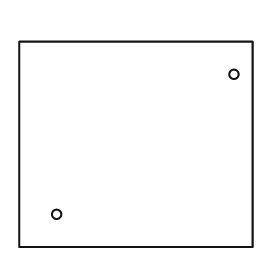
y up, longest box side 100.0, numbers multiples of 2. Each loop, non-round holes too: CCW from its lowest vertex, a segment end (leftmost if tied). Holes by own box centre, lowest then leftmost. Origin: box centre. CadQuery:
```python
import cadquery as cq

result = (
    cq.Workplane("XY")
    .moveTo(-50.0, -44.0)
    .lineTo(50.0, -44.0)
    .lineTo(50.0, 44.0)
    .lineTo(-50.0, 44.0)
    .close()
    .moveTo(-34.0, -30.0)
    .circle(2.0)
    .moveTo(42.0, 30.0)
    .circle(2.0)
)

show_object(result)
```